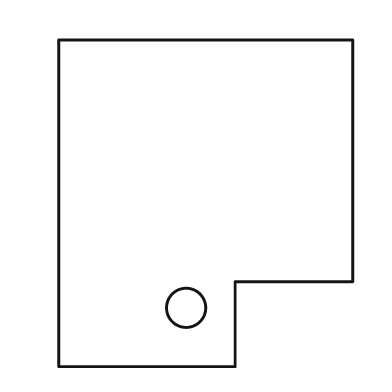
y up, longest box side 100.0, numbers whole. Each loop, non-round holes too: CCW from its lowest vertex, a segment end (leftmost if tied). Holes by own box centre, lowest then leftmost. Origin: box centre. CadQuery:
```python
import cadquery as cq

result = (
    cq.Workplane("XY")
    .moveTo(-45.0, -50.0)
    .lineTo(9.0, -50.0)
    .lineTo(9.0, -24.0)
    .lineTo(45.0, -24.0)
    .lineTo(45.0, 50.0)
    .lineTo(-45.0, 50.0)
    .close()
    .moveTo(-6.0, -32.0)
    .circle(6.0)
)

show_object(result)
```